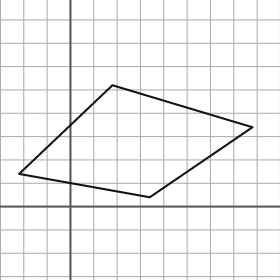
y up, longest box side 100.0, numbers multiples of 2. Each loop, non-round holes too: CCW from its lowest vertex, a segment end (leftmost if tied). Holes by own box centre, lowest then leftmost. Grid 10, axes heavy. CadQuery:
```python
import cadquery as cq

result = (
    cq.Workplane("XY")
    .moveTo(34.0, 4.0)
    .lineTo(78.0, 34.0)
    .lineTo(18.0, 52.0)
    .lineTo(-22.0, 14.0)
    .close()
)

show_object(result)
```